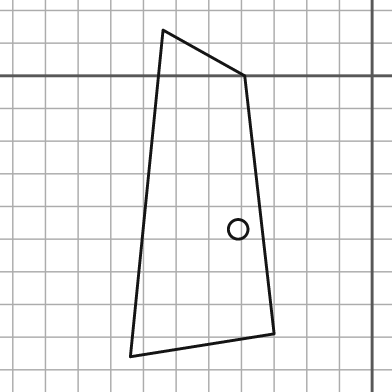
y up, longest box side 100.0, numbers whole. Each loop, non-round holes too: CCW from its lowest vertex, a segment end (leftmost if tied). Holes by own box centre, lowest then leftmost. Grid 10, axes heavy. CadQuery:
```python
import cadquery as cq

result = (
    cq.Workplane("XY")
    .moveTo(-74.0, -86.0)
    .lineTo(-30.0, -79.0)
    .lineTo(-39.0, 0.0)
    .lineTo(-64.0, 14.0)
    .close()
    .moveTo(-41.0, -47.0)
    .circle(3.0)
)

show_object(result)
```